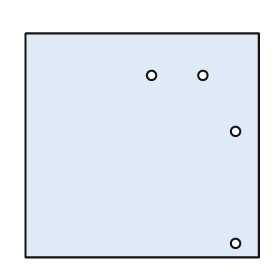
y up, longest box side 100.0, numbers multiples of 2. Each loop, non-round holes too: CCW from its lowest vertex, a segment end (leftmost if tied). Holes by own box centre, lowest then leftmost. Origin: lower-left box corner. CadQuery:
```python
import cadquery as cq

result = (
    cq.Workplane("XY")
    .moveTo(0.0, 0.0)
    .lineTo(100.0, 0.0)
    .lineTo(100.0, 96.0)
    .lineTo(0.0, 96.0)
    .close()
    .moveTo(90.0, 6.0)
    .circle(2.0)
    .moveTo(90.0, 54.0)
    .circle(2.0)
    .moveTo(54.0, 78.0)
    .circle(2.0)
    .moveTo(76.0, 78.0)
    .circle(2.0)
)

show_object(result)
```